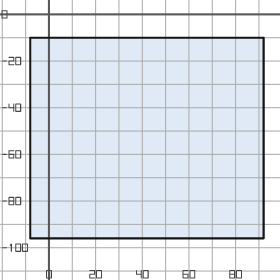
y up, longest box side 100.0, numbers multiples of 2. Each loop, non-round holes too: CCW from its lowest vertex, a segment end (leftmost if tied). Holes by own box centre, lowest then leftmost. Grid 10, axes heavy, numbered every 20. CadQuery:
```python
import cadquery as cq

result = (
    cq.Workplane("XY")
    .moveTo(-8.0, -96.0)
    .lineTo(92.0, -96.0)
    .lineTo(92.0, -10.0)
    .lineTo(-8.0, -10.0)
    .close()
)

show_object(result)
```